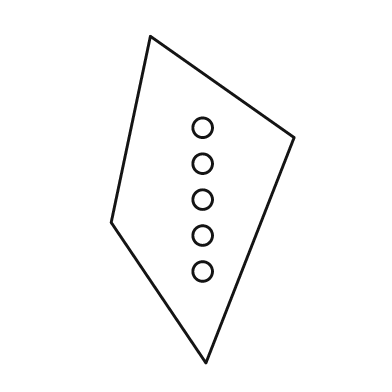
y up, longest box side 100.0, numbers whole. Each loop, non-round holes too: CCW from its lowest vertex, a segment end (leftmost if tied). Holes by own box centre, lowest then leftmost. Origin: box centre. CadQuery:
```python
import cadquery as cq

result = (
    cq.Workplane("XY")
    .moveTo(1.0, -50.0)
    .lineTo(28.0, 19.0)
    .lineTo(-16.0, 50.0)
    .lineTo(-28.0, -7.0)
    .close()
    .moveTo(0.0, -22.0)
    .circle(3.0)
    .moveTo(0.0, -11.0)
    .circle(3.0)
    .moveTo(0.0, 0.0)
    .circle(3.0)
    .moveTo(0.0, 11.0)
    .circle(3.0)
    .moveTo(0.0, 22.0)
    .circle(3.0)
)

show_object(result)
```